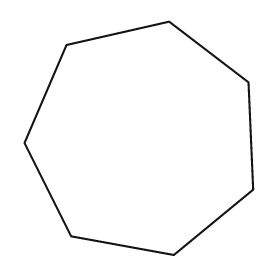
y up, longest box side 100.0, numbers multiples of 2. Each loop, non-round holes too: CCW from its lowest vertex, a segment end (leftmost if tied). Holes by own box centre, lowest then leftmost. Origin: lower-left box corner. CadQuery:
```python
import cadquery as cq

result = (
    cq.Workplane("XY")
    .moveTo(64.0, 0.0)
    .lineTo(98.0, 28.0)
    .lineTo(96.0, 74.0)
    .lineTo(62.0, 100.0)
    .lineTo(18.0, 90.0)
    .lineTo(0.0, 48.0)
    .lineTo(20.0, 8.0)
    .close()
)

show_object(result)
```